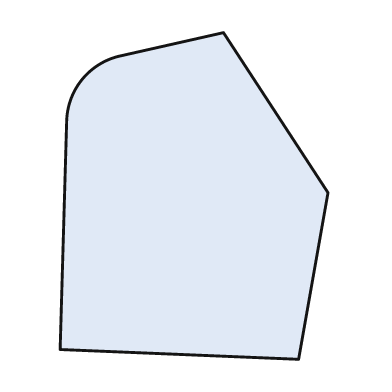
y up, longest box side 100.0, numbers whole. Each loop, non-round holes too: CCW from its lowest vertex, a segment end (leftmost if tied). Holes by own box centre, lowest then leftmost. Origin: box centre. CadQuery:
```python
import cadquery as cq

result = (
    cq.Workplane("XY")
    .moveTo(32.0, -50.0)
    .lineTo(41.0, 1.0)
    .lineTo(9.0, 50.0)
    .lineTo(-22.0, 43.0)
    .threePointArc((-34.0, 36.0), (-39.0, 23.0))
    .lineTo(-41.0, -47.0)
    .close()
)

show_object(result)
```